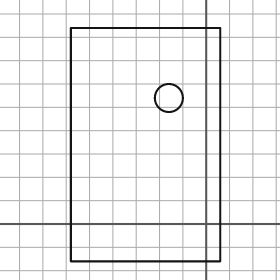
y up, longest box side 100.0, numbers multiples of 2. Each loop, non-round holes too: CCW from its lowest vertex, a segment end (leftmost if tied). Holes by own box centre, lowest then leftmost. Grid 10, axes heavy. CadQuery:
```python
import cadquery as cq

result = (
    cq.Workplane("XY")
    .moveTo(-58.0, -16.0)
    .lineTo(6.0, -16.0)
    .lineTo(6.0, 84.0)
    .lineTo(-58.0, 84.0)
    .close()
    .moveTo(-16.0, 54.0)
    .circle(6.0)
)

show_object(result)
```